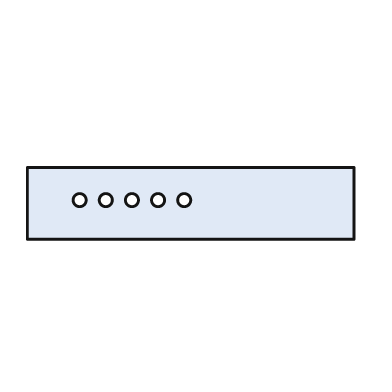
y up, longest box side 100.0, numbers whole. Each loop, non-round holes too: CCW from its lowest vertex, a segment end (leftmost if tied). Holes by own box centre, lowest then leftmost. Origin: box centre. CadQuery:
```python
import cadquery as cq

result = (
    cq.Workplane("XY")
    .moveTo(-50.0, -11.0)
    .lineTo(50.0, -11.0)
    .lineTo(50.0, 11.0)
    .lineTo(-50.0, 11.0)
    .close()
    .moveTo(-34.0, 1.0)
    .circle(2.0)
    .moveTo(-26.0, 1.0)
    .circle(2.0)
    .moveTo(-18.0, 1.0)
    .circle(2.0)
    .moveTo(-10.0, 1.0)
    .circle(2.0)
    .moveTo(-2.0, 1.0)
    .circle(2.0)
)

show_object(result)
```